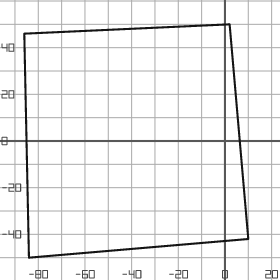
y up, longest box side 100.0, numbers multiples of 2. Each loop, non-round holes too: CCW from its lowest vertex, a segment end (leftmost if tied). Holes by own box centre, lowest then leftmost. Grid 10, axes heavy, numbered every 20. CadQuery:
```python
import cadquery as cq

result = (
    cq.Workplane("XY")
    .moveTo(-84.0, -50.0)
    .lineTo(10.0, -42.0)
    .lineTo(2.0, 50.0)
    .lineTo(-86.0, 46.0)
    .close()
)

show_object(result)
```